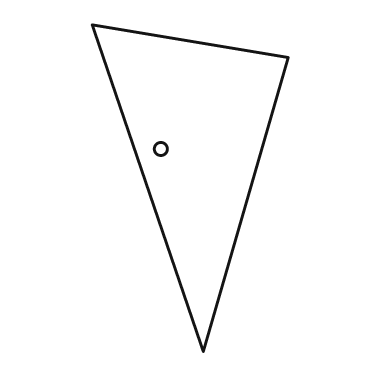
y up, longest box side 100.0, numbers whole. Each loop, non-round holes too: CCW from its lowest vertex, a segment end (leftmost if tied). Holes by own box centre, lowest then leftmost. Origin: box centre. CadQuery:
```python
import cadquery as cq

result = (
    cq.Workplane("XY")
    .moveTo(4.0, -50.0)
    .lineTo(30.0, 40.0)
    .lineTo(-30.0, 50.0)
    .close()
    .moveTo(-9.0, 12.0)
    .circle(2.0)
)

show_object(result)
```